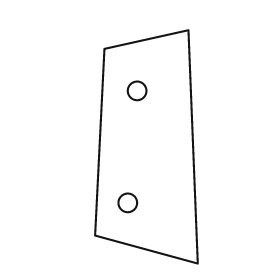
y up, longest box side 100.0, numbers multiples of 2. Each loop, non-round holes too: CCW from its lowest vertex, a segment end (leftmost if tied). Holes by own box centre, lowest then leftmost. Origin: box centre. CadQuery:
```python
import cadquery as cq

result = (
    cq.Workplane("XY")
    .moveTo(22.0, -50.0)
    .lineTo(18.0, 50.0)
    .lineTo(-18.0, 42.0)
    .lineTo(-22.0, -38.0)
    .close()
    .moveTo(-8.0, -24.0)
    .circle(4.0)
    .moveTo(-4.0, 24.0)
    .circle(4.0)
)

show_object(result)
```